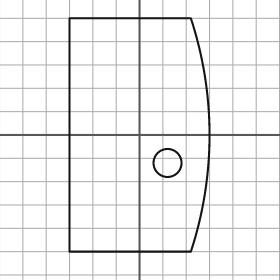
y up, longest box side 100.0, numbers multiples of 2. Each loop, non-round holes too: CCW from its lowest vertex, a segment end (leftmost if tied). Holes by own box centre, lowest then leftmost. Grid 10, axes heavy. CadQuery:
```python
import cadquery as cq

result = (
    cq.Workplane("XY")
    .moveTo(-30.0, -50.0)
    .lineTo(22.0, -50.0)
    .threePointArc((30.0, 0.0), (22.0, 50.0))
    .lineTo(-30.0, 50.0)
    .close()
    .moveTo(12.0, -12.0)
    .circle(6.0)
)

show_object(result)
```